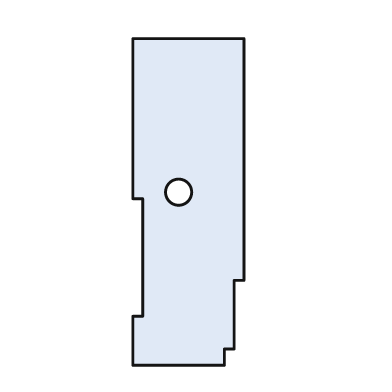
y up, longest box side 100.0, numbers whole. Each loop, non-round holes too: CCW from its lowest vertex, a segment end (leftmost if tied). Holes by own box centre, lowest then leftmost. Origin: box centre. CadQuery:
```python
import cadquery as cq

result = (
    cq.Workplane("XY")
    .moveTo(-17.0, -50.0)
    .lineTo(11.0, -50.0)
    .lineTo(11.0, -45.0)
    .lineTo(14.0, -45.0)
    .lineTo(14.0, -24.0)
    .lineTo(17.0, -24.0)
    .lineTo(17.0, 50.0)
    .lineTo(-17.0, 50.0)
    .lineTo(-17.0, 1.0)
    .lineTo(-14.0, 1.0)
    .lineTo(-14.0, -35.0)
    .lineTo(-17.0, -35.0)
    .close()
    .moveTo(-3.0, 3.0)
    .circle(4.0)
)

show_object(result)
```